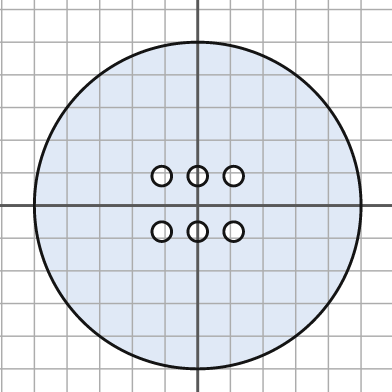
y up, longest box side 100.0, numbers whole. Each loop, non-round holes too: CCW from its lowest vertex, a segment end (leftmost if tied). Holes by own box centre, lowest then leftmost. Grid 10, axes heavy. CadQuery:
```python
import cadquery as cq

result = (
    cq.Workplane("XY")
    .moveTo(0.0, 0.0)
    .circle(50.0)
    .moveTo(-11.0, -8.0)
    .circle(3.0)
    .moveTo(0.0, -8.0)
    .circle(3.0)
    .moveTo(11.0, -8.0)
    .circle(3.0)
    .moveTo(-11.0, 9.0)
    .circle(3.0)
    .moveTo(0.0, 9.0)
    .circle(3.0)
    .moveTo(11.0, 9.0)
    .circle(3.0)
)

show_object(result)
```